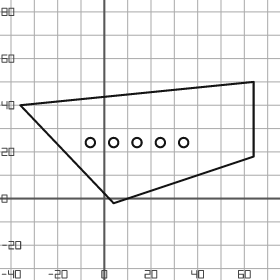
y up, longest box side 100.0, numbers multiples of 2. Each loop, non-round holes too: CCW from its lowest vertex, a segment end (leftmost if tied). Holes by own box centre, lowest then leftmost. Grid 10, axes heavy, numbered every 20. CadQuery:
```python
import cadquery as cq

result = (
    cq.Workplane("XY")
    .moveTo(4.0, -2.0)
    .lineTo(64.0, 18.0)
    .lineTo(64.0, 50.0)
    .lineTo(-36.0, 40.0)
    .close()
    .moveTo(-6.0, 24.0)
    .circle(2.0)
    .moveTo(4.0, 24.0)
    .circle(2.0)
    .moveTo(14.0, 24.0)
    .circle(2.0)
    .moveTo(24.0, 24.0)
    .circle(2.0)
    .moveTo(34.0, 24.0)
    .circle(2.0)
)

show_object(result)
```